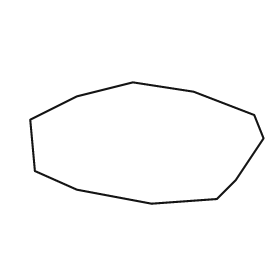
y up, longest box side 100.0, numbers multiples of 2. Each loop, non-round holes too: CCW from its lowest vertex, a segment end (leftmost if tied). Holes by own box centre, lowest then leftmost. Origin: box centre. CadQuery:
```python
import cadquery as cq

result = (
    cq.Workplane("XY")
    .moveTo(2.0, -26.0)
    .lineTo(30.0, -24.0)
    .lineTo(38.0, -16.0)
    .lineTo(50.0, 2.0)
    .lineTo(46.0, 12.0)
    .lineTo(20.0, 22.0)
    .lineTo(-6.0, 26.0)
    .lineTo(-30.0, 20.0)
    .lineTo(-50.0, 10.0)
    .lineTo(-48.0, -12.0)
    .lineTo(-30.0, -20.0)
    .close()
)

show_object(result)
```